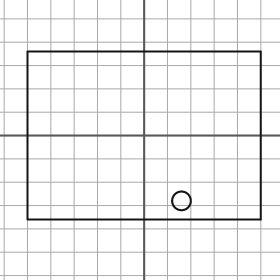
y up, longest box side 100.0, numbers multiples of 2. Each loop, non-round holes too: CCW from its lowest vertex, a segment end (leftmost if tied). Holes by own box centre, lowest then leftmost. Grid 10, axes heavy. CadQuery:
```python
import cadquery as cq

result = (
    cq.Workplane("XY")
    .moveTo(-50.0, -36.0)
    .lineTo(50.0, -36.0)
    .lineTo(50.0, 36.0)
    .lineTo(-50.0, 36.0)
    .close()
    .moveTo(16.0, -28.0)
    .circle(4.0)
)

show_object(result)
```